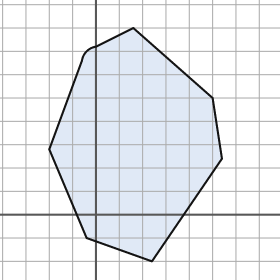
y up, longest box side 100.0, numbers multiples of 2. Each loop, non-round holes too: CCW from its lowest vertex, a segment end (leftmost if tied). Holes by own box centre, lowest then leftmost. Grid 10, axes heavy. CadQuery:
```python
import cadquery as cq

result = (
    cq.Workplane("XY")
    .moveTo(24.0, -20.0)
    .lineTo(54.0, 24.0)
    .lineTo(50.0, 50.0)
    .lineTo(16.0, 80.0)
    .lineTo(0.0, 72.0)
    .threePointArc((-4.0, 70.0), (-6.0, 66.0))
    .lineTo(-20.0, 28.0)
    .lineTo(-4.0, -10.0)
    .close()
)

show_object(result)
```